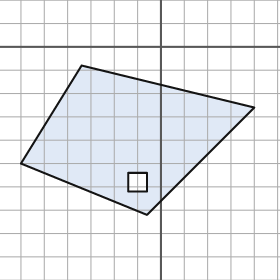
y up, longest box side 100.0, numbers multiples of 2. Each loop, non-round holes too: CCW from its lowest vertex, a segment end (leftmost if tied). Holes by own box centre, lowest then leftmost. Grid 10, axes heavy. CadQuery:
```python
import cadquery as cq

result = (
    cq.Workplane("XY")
    .moveTo(-6.0, -72.0)
    .lineTo(40.0, -26.0)
    .lineTo(-34.0, -8.0)
    .lineTo(-60.0, -50.0)
    .close()
    .moveTo(-14.0, -62.0)
    .lineTo(-6.0, -62.0)
    .lineTo(-6.0, -54.0)
    .lineTo(-14.0, -54.0)
    .close()
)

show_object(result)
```